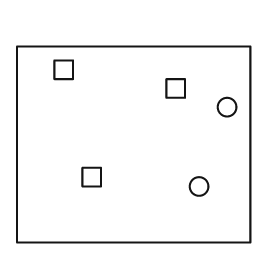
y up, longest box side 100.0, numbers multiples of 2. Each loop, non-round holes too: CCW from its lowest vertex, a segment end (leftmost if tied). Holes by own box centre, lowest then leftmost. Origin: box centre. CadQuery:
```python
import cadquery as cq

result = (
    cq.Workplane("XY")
    .moveTo(-50.0, -42.0)
    .lineTo(50.0, -42.0)
    .lineTo(50.0, 42.0)
    .lineTo(-50.0, 42.0)
    .close()
    .moveTo(28.0, -18.0)
    .circle(4.0)
    .moveTo(-22.0, -18.0)
    .lineTo(-14.0, -18.0)
    .lineTo(-14.0, -10.0)
    .lineTo(-22.0, -10.0)
    .close()
    .moveTo(40.0, 16.0)
    .circle(4.0)
    .moveTo(14.0, 20.0)
    .lineTo(22.0, 20.0)
    .lineTo(22.0, 28.0)
    .lineTo(14.0, 28.0)
    .close()
    .moveTo(-34.0, 28.0)
    .lineTo(-26.0, 28.0)
    .lineTo(-26.0, 36.0)
    .lineTo(-34.0, 36.0)
    .close()
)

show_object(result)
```